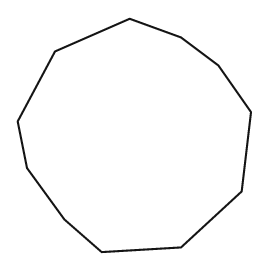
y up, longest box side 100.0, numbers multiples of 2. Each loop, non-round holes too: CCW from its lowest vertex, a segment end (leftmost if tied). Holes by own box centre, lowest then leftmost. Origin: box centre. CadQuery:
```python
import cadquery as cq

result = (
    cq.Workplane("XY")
    .moveTo(-14.0, -50.0)
    .lineTo(20.0, -48.0)
    .lineTo(46.0, -24.0)
    .lineTo(50.0, 10.0)
    .lineTo(36.0, 30.0)
    .lineTo(20.0, 42.0)
    .lineTo(-2.0, 50.0)
    .lineTo(-34.0, 36.0)
    .lineTo(-50.0, 6.0)
    .lineTo(-46.0, -14.0)
    .lineTo(-30.0, -36.0)
    .close()
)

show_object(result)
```